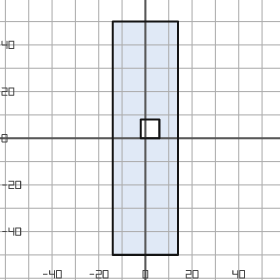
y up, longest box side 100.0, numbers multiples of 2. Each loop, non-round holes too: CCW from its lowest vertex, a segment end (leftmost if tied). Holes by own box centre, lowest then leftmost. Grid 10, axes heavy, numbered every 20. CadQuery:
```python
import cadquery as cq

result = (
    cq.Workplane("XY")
    .moveTo(-14.0, -50.0)
    .lineTo(14.0, -50.0)
    .lineTo(14.0, 50.0)
    .lineTo(-14.0, 50.0)
    .close()
    .moveTo(-2.0, 0.0)
    .lineTo(6.0, 0.0)
    .lineTo(6.0, 8.0)
    .lineTo(-2.0, 8.0)
    .close()
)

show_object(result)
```